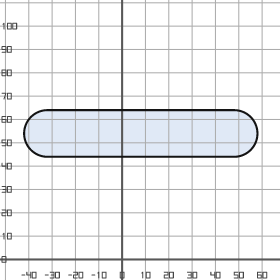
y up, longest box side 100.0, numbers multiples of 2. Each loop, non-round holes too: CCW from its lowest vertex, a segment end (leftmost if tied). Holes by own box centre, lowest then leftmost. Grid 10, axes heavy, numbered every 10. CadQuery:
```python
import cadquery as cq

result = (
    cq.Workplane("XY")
    .moveTo(-32.0, 44.0)
    .lineTo(48.0, 44.0)
    .threePointArc((58.0, 54.0), (48.0, 64.0))
    .lineTo(-32.0, 64.0)
    .threePointArc((-42.0, 54.0), (-32.0, 44.0))
    .close()
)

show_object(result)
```